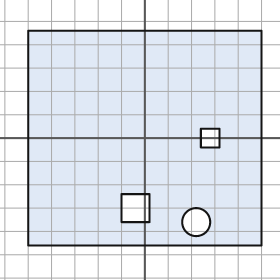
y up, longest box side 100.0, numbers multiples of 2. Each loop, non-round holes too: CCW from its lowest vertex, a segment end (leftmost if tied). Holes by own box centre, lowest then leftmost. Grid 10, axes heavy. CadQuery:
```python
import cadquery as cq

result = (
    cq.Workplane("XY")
    .moveTo(-50.0, -46.0)
    .lineTo(50.0, -46.0)
    .lineTo(50.0, 46.0)
    .lineTo(-50.0, 46.0)
    .close()
    .moveTo(22.0, -36.0)
    .circle(6.0)
    .moveTo(-10.0, -36.0)
    .lineTo(2.0, -36.0)
    .lineTo(2.0, -24.0)
    .lineTo(-10.0, -24.0)
    .close()
    .moveTo(24.0, -4.0)
    .lineTo(32.0, -4.0)
    .lineTo(32.0, 4.0)
    .lineTo(24.0, 4.0)
    .close()
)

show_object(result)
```